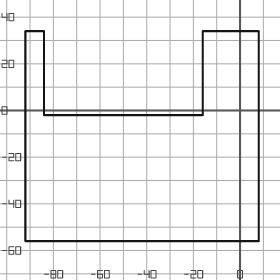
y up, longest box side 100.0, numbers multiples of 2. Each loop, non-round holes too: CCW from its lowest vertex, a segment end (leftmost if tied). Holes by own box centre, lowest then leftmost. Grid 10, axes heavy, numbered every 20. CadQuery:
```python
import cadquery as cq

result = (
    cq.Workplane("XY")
    .moveTo(-92.0, -56.0)
    .lineTo(8.0, -56.0)
    .lineTo(8.0, 34.0)
    .lineTo(-16.0, 34.0)
    .lineTo(-16.0, -2.0)
    .lineTo(-84.0, -2.0)
    .lineTo(-84.0, 34.0)
    .lineTo(-92.0, 34.0)
    .close()
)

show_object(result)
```